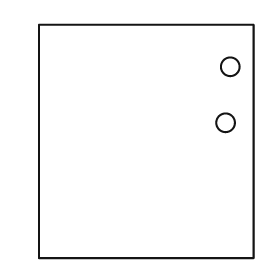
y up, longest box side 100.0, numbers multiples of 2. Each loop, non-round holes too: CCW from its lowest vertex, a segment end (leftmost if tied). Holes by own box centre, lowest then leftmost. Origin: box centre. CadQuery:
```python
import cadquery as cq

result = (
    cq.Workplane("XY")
    .moveTo(-46.0, -50.0)
    .lineTo(46.0, -50.0)
    .lineTo(46.0, 50.0)
    .lineTo(-46.0, 50.0)
    .close()
    .moveTo(34.0, 8.0)
    .circle(4.0)
    .moveTo(36.0, 32.0)
    .circle(4.0)
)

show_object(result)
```